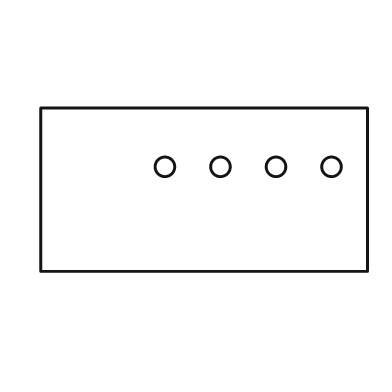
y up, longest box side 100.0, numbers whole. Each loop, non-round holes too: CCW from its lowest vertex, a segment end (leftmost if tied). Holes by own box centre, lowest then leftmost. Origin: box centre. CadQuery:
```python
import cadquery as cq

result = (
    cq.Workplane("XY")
    .moveTo(-50.0, -25.0)
    .lineTo(50.0, -25.0)
    .lineTo(50.0, 25.0)
    .lineTo(-50.0, 25.0)
    .close()
    .moveTo(-12.0, 7.0)
    .circle(3.0)
    .moveTo(5.0, 7.0)
    .circle(3.0)
    .moveTo(22.0, 7.0)
    .circle(3.0)
    .moveTo(39.0, 7.0)
    .circle(3.0)
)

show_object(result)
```